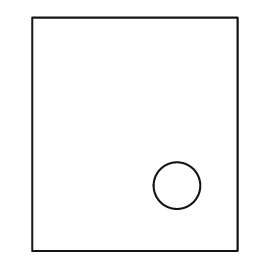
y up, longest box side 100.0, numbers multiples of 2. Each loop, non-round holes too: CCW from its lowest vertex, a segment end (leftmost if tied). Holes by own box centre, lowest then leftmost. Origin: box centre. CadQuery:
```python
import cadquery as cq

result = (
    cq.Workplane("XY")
    .moveTo(-44.0, -50.0)
    .lineTo(44.0, -50.0)
    .lineTo(44.0, 50.0)
    .lineTo(-44.0, 50.0)
    .close()
    .moveTo(18.0, -22.0)
    .circle(10.0)
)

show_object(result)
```